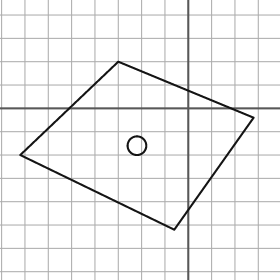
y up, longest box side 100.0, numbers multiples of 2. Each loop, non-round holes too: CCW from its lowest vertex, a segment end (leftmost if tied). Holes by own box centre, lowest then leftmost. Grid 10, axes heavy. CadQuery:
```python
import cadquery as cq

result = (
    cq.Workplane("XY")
    .moveTo(-6.0, -52.0)
    .lineTo(28.0, -4.0)
    .lineTo(-30.0, 20.0)
    .lineTo(-72.0, -20.0)
    .close()
    .moveTo(-22.0, -16.0)
    .circle(4.0)
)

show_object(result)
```